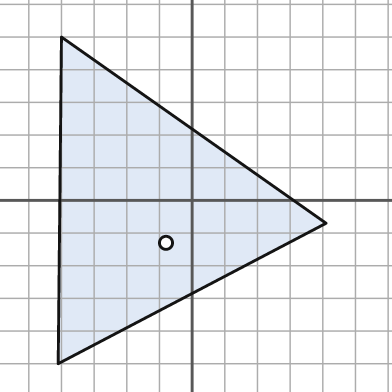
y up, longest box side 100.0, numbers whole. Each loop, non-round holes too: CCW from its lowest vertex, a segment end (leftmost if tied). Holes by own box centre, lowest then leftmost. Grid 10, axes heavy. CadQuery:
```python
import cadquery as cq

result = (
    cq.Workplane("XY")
    .moveTo(-41.0, -50.0)
    .lineTo(41.0, -7.0)
    .lineTo(-40.0, 50.0)
    .close()
    .moveTo(-8.0, -13.0)
    .circle(2.0)
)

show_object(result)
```